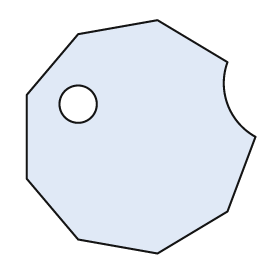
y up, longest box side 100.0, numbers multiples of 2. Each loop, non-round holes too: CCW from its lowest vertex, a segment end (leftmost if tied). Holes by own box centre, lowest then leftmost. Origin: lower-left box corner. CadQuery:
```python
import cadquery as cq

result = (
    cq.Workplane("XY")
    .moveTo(56.0, 0.0)
    .lineTo(86.0, 18.0)
    .lineTo(98.0, 50.0)
    .threePointArc((86.0, 64.0), (86.0, 82.0))
    .lineTo(56.0, 100.0)
    .lineTo(22.0, 94.0)
    .lineTo(0.0, 68.0)
    .lineTo(0.0, 32.0)
    .lineTo(22.0, 6.0)
    .close()
    .moveTo(22.0, 64.0)
    .circle(8.0)
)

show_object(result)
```